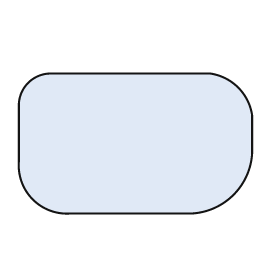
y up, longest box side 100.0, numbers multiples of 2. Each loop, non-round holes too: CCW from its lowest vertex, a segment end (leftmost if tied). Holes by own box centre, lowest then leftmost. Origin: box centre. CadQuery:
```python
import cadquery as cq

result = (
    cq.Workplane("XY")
    .moveTo(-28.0, -30.0)
    .lineTo(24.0, -30.0)
    .threePointArc((42.0, -22.0), (50.0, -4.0))
    .lineTo(50.0, 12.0)
    .threePointArc((44.0, 24.0), (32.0, 30.0))
    .lineTo(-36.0, 30.0)
    .threePointArc((-46.0, 26.0), (-50.0, 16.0))
    .lineTo(-50.0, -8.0)
    .threePointArc((-44.0, -24.0), (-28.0, -30.0))
    .close()
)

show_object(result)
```